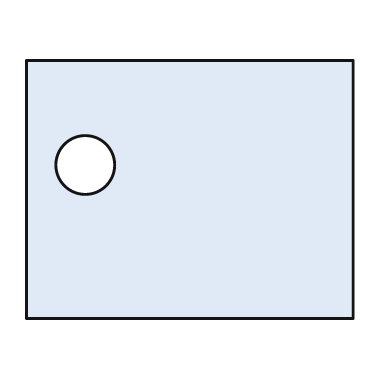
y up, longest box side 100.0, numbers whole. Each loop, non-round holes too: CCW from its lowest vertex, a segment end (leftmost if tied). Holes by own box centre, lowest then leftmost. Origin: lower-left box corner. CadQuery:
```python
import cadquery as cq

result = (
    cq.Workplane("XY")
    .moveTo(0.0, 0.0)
    .lineTo(100.0, 0.0)
    .lineTo(100.0, 79.0)
    .lineTo(0.0, 79.0)
    .close()
    .moveTo(18.0, 47.0)
    .circle(9.0)
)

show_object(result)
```